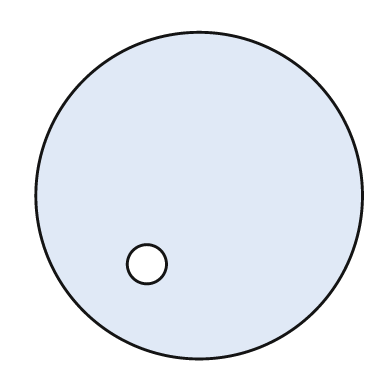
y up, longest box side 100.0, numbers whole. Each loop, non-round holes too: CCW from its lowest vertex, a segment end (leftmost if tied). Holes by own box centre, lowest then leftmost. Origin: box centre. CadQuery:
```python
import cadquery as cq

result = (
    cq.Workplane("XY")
    .moveTo(0.0, 0.0)
    .circle(50.0)
    .moveTo(-16.0, -21.0)
    .circle(6.0)
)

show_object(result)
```